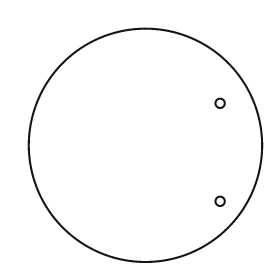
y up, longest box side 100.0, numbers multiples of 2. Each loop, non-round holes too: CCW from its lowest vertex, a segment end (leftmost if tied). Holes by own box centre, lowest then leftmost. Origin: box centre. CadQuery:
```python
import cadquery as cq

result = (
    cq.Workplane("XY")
    .moveTo(0.0, 0.0)
    .circle(50.0)
    .moveTo(32.0, -24.0)
    .circle(2.0)
    .moveTo(32.0, 18.0)
    .circle(2.0)
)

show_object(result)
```